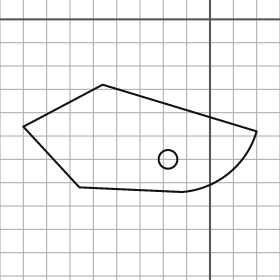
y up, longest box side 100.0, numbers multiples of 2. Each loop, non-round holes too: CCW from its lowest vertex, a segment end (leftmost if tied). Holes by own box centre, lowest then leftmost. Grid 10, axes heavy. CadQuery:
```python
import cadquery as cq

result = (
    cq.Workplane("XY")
    .moveTo(-12.0, -74.0)
    .threePointArc((8.0, -66.0), (20.0, -48.0))
    .lineTo(-46.0, -28.0)
    .lineTo(-80.0, -46.0)
    .lineTo(-56.0, -72.0)
    .close()
    .moveTo(-18.0, -60.0)
    .circle(4.0)
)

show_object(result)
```